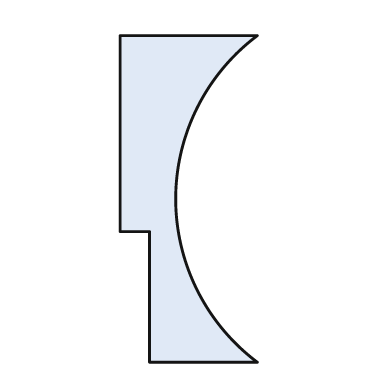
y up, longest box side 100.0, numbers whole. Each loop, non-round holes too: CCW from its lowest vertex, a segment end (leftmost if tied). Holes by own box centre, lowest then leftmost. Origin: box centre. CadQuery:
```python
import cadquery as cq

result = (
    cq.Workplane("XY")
    .moveTo(-12.0, -50.0)
    .lineTo(21.0, -50.0)
    .threePointArc((-4.0, 0.0), (21.0, 50.0))
    .lineTo(-21.0, 50.0)
    .lineTo(-21.0, -10.0)
    .lineTo(-12.0, -10.0)
    .close()
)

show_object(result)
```